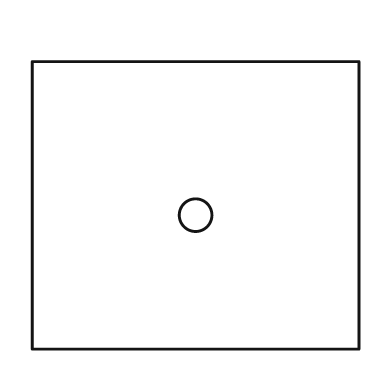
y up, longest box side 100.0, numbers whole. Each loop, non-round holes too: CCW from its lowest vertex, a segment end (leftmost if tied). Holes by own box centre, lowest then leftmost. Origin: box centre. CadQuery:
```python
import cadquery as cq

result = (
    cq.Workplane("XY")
    .moveTo(-50.0, -44.0)
    .lineTo(50.0, -44.0)
    .lineTo(50.0, 44.0)
    .lineTo(-50.0, 44.0)
    .close()
    .moveTo(0.0, -3.0)
    .circle(5.0)
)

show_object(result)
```